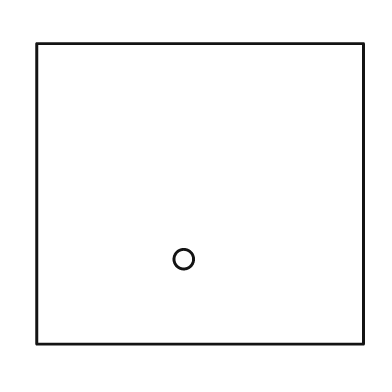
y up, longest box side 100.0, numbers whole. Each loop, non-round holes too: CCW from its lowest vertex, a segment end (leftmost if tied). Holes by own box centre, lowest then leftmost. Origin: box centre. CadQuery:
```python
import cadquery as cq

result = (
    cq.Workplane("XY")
    .moveTo(-50.0, -46.0)
    .lineTo(50.0, -46.0)
    .lineTo(50.0, 46.0)
    .lineTo(-50.0, 46.0)
    .close()
    .moveTo(-5.0, -20.0)
    .circle(3.0)
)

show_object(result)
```